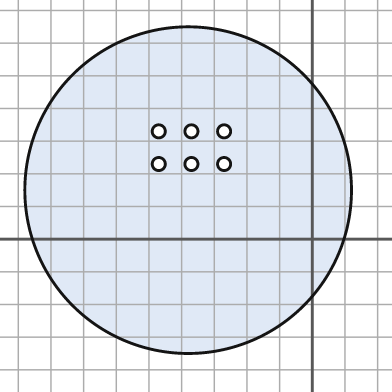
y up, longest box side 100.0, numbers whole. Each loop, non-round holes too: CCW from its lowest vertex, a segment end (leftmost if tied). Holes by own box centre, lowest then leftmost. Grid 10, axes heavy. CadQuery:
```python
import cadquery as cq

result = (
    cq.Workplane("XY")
    .moveTo(-38.0, 15.0)
    .circle(50.0)
    .moveTo(-47.0, 23.0)
    .circle(2.0)
    .moveTo(-37.0, 23.0)
    .circle(2.0)
    .moveTo(-27.0, 23.0)
    .circle(2.0)
    .moveTo(-47.0, 33.0)
    .circle(2.0)
    .moveTo(-37.0, 33.0)
    .circle(2.0)
    .moveTo(-27.0, 33.0)
    .circle(2.0)
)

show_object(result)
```